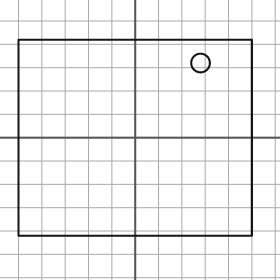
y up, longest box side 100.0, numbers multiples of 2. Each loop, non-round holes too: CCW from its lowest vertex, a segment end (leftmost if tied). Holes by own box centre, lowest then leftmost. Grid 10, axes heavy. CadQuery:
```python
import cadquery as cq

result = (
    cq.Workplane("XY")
    .moveTo(-50.0, -42.0)
    .lineTo(50.0, -42.0)
    .lineTo(50.0, 42.0)
    .lineTo(-50.0, 42.0)
    .close()
    .moveTo(28.0, 32.0)
    .circle(4.0)
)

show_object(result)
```